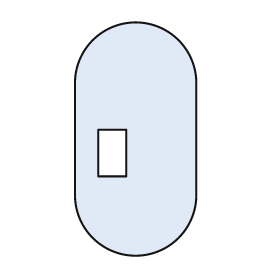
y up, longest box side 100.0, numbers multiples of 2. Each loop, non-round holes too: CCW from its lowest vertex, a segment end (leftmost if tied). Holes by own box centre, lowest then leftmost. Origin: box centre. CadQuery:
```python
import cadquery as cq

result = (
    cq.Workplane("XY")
    .moveTo(-26.0, -24.0)
    .threePointArc((0.0, -50.0), (26.0, -24.0))
    .lineTo(26.0, 24.0)
    .threePointArc((0.0, 50.0), (-26.0, 24.0))
    .close()
    .moveTo(-16.0, -16.0)
    .lineTo(-4.0, -16.0)
    .lineTo(-4.0, 4.0)
    .lineTo(-16.0, 4.0)
    .close()
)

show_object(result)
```